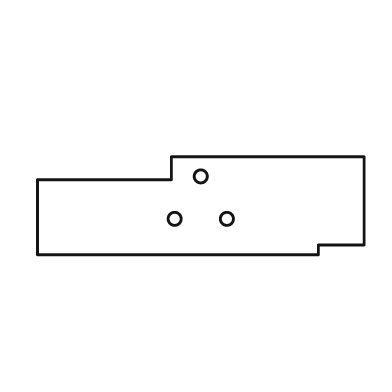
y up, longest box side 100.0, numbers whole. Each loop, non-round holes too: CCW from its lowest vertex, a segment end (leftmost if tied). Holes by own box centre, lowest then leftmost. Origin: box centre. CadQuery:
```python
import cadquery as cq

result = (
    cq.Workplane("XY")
    .moveTo(-50.0, -15.0)
    .lineTo(36.0, -15.0)
    .lineTo(36.0, -12.0)
    .lineTo(50.0, -12.0)
    .lineTo(50.0, 15.0)
    .lineTo(-9.0, 15.0)
    .lineTo(-9.0, 8.0)
    .lineTo(-50.0, 8.0)
    .close()
    .moveTo(-8.0, -4.0)
    .circle(2.0)
    .moveTo(8.0, -4.0)
    .circle(2.0)
    .moveTo(0.0, 9.0)
    .circle(2.0)
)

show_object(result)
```